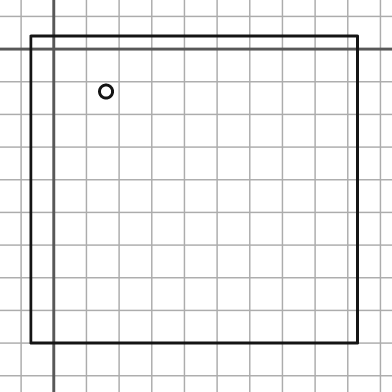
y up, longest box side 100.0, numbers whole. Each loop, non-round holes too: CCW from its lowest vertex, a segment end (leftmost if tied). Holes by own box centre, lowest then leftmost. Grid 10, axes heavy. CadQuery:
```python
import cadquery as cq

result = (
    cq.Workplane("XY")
    .moveTo(-7.0, -90.0)
    .lineTo(93.0, -90.0)
    .lineTo(93.0, 4.0)
    .lineTo(-7.0, 4.0)
    .close()
    .moveTo(16.0, -13.0)
    .circle(2.0)
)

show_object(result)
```